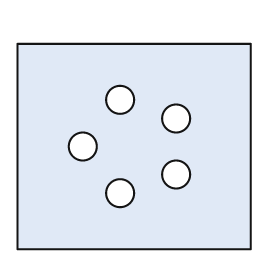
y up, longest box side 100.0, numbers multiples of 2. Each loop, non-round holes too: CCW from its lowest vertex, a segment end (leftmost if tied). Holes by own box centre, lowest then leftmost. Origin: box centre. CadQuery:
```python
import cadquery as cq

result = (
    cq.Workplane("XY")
    .moveTo(-50.0, -44.0)
    .lineTo(50.0, -44.0)
    .lineTo(50.0, 44.0)
    .lineTo(-50.0, 44.0)
    .close()
    .moveTo(-6.0, -20.0)
    .circle(6.0)
    .moveTo(18.0, -12.0)
    .circle(6.0)
    .moveTo(-22.0, 0.0)
    .circle(6.0)
    .moveTo(18.0, 12.0)
    .circle(6.0)
    .moveTo(-6.0, 20.0)
    .circle(6.0)
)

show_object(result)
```